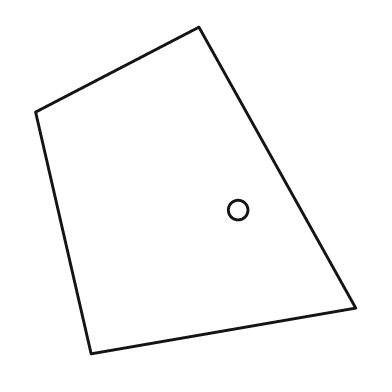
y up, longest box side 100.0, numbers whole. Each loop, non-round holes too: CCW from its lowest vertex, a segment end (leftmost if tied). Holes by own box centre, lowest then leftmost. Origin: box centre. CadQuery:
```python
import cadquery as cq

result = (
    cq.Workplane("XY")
    .moveTo(-32.0, -50.0)
    .lineTo(49.0, -36.0)
    .lineTo(1.0, 50.0)
    .lineTo(-49.0, 24.0)
    .close()
    .moveTo(13.0, -6.0)
    .circle(3.0)
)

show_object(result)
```